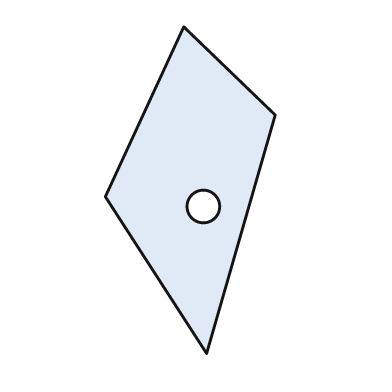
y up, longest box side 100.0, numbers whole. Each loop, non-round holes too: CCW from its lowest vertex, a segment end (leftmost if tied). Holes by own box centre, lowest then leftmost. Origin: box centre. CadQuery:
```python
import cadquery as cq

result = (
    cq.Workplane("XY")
    .moveTo(5.0, -50.0)
    .lineTo(26.0, 23.0)
    .lineTo(-2.0, 50.0)
    .lineTo(-26.0, -2.0)
    .close()
    .moveTo(4.0, -5.0)
    .circle(5.0)
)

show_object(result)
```